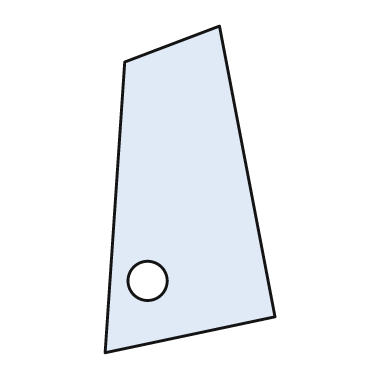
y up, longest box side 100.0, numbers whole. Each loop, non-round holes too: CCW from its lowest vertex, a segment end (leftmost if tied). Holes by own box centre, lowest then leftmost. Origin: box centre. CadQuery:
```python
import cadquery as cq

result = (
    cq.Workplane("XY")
    .moveTo(-26.0, -50.0)
    .lineTo(26.0, -39.0)
    .lineTo(9.0, 50.0)
    .lineTo(-20.0, 39.0)
    .close()
    .moveTo(-13.0, -28.0)
    .circle(6.0)
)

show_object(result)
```